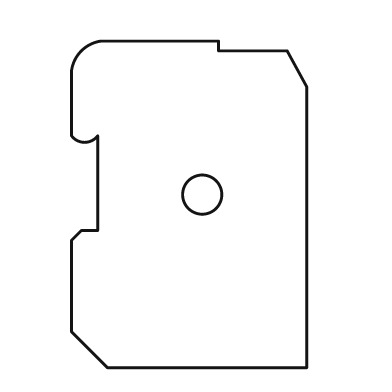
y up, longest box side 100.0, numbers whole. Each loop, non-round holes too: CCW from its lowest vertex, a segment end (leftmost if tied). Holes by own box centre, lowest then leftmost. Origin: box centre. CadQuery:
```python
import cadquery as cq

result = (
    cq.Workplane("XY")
    .moveTo(-25.0, -50.0)
    .lineTo(36.0, -50.0)
    .lineTo(36.0, 36.0)
    .lineTo(30.0, 47.0)
    .lineTo(9.0, 47.0)
    .lineTo(9.0, 50.0)
    .lineTo(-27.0, 50.0)
    .threePointArc((-33.0, 47.0), (-36.0, 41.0))
    .lineTo(-36.0, 21.0)
    .threePointArc((-32.0, 19.0), (-28.0, 21.0))
    .lineTo(-28.0, -8.0)
    .lineTo(-33.0, -8.0)
    .lineTo(-36.0, -11.0)
    .lineTo(-36.0, -39.0)
    .close()
    .moveTo(4.0, 3.0)
    .circle(6.0)
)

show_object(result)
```